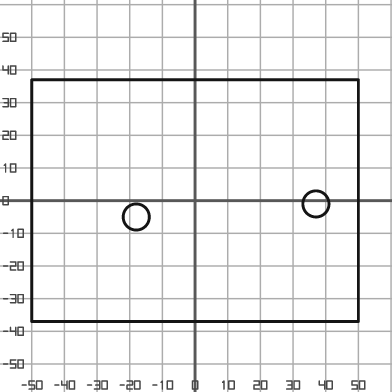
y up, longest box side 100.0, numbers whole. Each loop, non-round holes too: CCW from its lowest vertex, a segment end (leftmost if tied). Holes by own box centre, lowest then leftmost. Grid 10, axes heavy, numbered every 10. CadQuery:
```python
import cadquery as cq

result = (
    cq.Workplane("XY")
    .moveTo(-50.0, -37.0)
    .lineTo(50.0, -37.0)
    .lineTo(50.0, 37.0)
    .lineTo(-50.0, 37.0)
    .close()
    .moveTo(-18.0, -5.0)
    .circle(4.0)
    .moveTo(37.0, -1.0)
    .circle(4.0)
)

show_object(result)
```